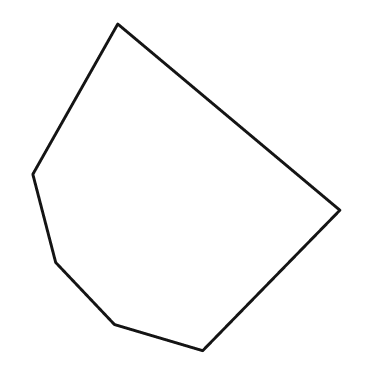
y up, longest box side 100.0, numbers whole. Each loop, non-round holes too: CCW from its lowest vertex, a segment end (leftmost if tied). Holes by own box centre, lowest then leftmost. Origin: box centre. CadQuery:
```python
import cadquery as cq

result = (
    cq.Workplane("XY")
    .moveTo(5.0, -50.0)
    .lineTo(47.0, -7.0)
    .lineTo(-21.0, 50.0)
    .lineTo(-47.0, 4.0)
    .lineTo(-40.0, -23.0)
    .lineTo(-22.0, -42.0)
    .close()
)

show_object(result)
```